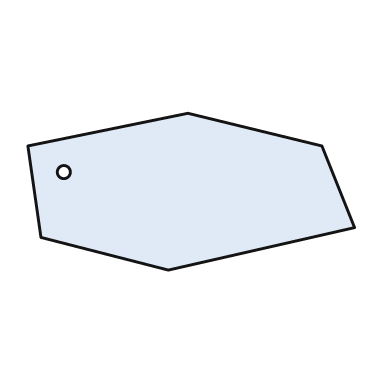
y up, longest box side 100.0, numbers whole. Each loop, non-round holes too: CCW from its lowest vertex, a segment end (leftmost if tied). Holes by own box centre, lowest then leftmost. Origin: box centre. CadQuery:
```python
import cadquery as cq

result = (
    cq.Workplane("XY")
    .moveTo(-7.0, -24.0)
    .lineTo(50.0, -11.0)
    .lineTo(40.0, 14.0)
    .lineTo(-1.0, 24.0)
    .lineTo(-50.0, 14.0)
    .lineTo(-46.0, -14.0)
    .close()
    .moveTo(-39.0, 6.0)
    .circle(2.0)
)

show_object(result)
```